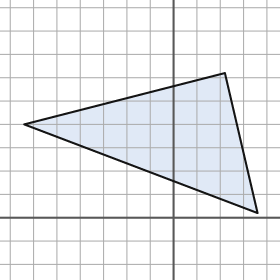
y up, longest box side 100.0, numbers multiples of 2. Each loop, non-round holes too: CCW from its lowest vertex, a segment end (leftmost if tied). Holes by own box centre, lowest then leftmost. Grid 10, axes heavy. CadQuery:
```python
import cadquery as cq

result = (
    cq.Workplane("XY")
    .moveTo(36.0, 2.0)
    .lineTo(22.0, 62.0)
    .lineTo(-64.0, 40.0)
    .close()
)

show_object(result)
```